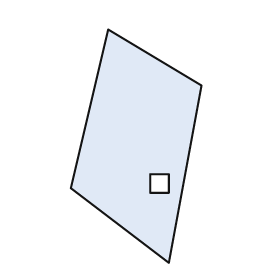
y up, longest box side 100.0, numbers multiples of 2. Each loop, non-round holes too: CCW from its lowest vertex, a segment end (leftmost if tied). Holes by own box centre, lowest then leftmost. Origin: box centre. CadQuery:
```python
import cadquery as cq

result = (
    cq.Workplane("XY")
    .moveTo(14.0, -50.0)
    .lineTo(28.0, 26.0)
    .lineTo(-12.0, 50.0)
    .lineTo(-28.0, -18.0)
    .close()
    .moveTo(6.0, -20.0)
    .lineTo(14.0, -20.0)
    .lineTo(14.0, -12.0)
    .lineTo(6.0, -12.0)
    .close()
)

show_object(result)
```